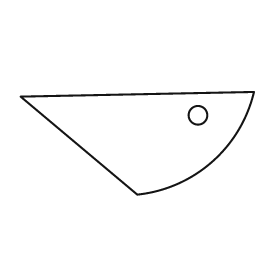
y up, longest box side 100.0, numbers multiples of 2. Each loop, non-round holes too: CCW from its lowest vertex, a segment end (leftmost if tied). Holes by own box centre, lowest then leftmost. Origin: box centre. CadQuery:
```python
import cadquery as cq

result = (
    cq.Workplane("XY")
    .moveTo(0.0, -22.0)
    .threePointArc((32.0, -8.0), (50.0, 22.0))
    .lineTo(-50.0, 20.0)
    .close()
    .moveTo(26.0, 12.0)
    .circle(4.0)
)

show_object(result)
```